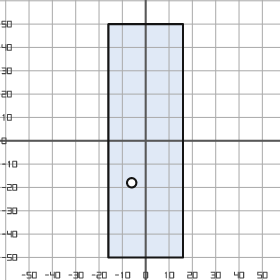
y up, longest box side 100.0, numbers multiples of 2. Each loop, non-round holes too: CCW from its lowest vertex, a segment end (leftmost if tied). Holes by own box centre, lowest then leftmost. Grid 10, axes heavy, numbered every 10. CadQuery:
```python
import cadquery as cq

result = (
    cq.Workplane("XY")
    .moveTo(-16.0, -50.0)
    .lineTo(16.0, -50.0)
    .lineTo(16.0, 50.0)
    .lineTo(-16.0, 50.0)
    .close()
    .moveTo(-6.0, -18.0)
    .circle(2.0)
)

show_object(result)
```